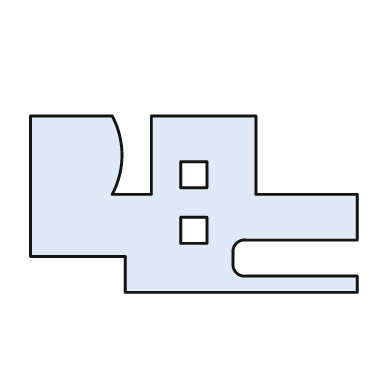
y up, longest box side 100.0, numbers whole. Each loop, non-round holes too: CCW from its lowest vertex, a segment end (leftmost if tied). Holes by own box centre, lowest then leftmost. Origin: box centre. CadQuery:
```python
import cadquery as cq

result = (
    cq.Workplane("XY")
    .moveTo(-21.0, -27.0)
    .lineTo(50.0, -27.0)
    .lineTo(50.0, -22.0)
    .lineTo(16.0, -22.0)
    .threePointArc((13.0, -21.0), (12.0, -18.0))
    .lineTo(12.0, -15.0)
    .threePointArc((13.0, -12.0), (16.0, -11.0))
    .lineTo(50.0, -11.0)
    .lineTo(50.0, 3.0)
    .lineTo(19.0, 3.0)
    .lineTo(19.0, 27.0)
    .lineTo(-13.0, 27.0)
    .lineTo(-13.0, 3.0)
    .lineTo(-25.0, 3.0)
    .threePointArc((-22.0, 15.0), (-25.0, 27.0))
    .lineTo(-50.0, 27.0)
    .lineTo(-50.0, -16.0)
    .lineTo(-21.0, -16.0)
    .close()
    .moveTo(-4.0, -12.0)
    .lineTo(4.0, -12.0)
    .lineTo(4.0, -4.0)
    .lineTo(-4.0, -4.0)
    .close()
    .moveTo(-4.0, 5.0)
    .lineTo(4.0, 5.0)
    .lineTo(4.0, 13.0)
    .lineTo(-4.0, 13.0)
    .close()
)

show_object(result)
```